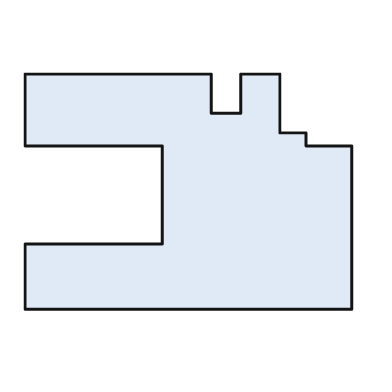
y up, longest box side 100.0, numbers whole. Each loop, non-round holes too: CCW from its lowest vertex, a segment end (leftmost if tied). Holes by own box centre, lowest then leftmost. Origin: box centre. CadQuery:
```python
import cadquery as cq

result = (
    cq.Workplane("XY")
    .moveTo(-50.0, -36.0)
    .lineTo(50.0, -36.0)
    .lineTo(50.0, 14.0)
    .lineTo(36.0, 14.0)
    .lineTo(36.0, 18.0)
    .lineTo(28.0, 18.0)
    .lineTo(28.0, 36.0)
    .lineTo(16.0, 36.0)
    .lineTo(16.0, 24.0)
    .lineTo(7.0, 24.0)
    .lineTo(7.0, 36.0)
    .lineTo(-50.0, 36.0)
    .lineTo(-50.0, 14.0)
    .lineTo(-8.0, 14.0)
    .lineTo(-8.0, -16.0)
    .lineTo(-50.0, -16.0)
    .close()
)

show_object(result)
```